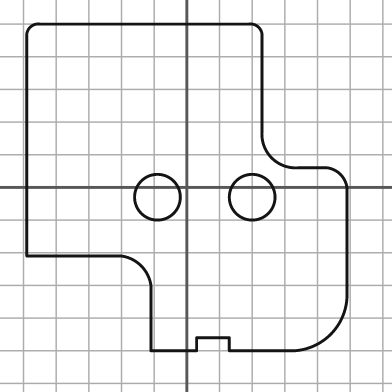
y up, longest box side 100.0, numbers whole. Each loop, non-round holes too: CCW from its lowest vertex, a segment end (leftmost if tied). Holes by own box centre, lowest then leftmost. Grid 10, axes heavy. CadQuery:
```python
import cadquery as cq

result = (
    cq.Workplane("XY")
    .moveTo(-11.0, -50.0)
    .lineTo(3.0, -50.0)
    .lineTo(3.0, -46.0)
    .lineTo(13.0, -46.0)
    .lineTo(13.0, -50.0)
    .lineTo(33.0, -50.0)
    .threePointArc((44.0, -45.0), (49.0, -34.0))
    .lineTo(49.0, 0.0)
    .threePointArc((47.0, 4.0), (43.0, 6.0))
    .lineTo(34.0, 6.0)
    .threePointArc((26.0, 9.0), (23.0, 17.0))
    .lineTo(23.0, 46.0)
    .threePointArc((22.0, 49.0), (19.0, 50.0))
    .lineTo(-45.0, 50.0)
    .threePointArc((-48.0, 49.0), (-49.0, 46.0))
    .lineTo(-49.0, -21.0)
    .lineTo(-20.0, -21.0)
    .threePointArc((-14.0, -24.0), (-11.0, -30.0))
    .close()
    .moveTo(-9.0, -3.0)
    .circle(7.0)
    .moveTo(20.0, -3.0)
    .circle(7.0)
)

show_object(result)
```